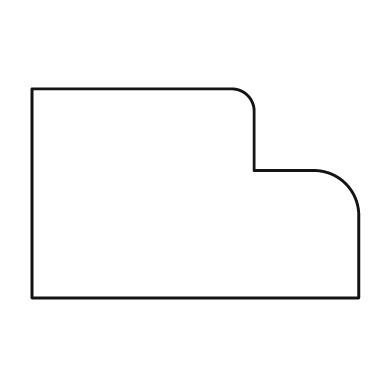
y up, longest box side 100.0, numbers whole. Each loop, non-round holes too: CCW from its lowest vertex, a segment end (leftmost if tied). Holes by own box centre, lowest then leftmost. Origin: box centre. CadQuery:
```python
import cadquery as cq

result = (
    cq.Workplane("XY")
    .moveTo(-50.0, -32.0)
    .lineTo(50.0, -32.0)
    .lineTo(50.0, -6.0)
    .threePointArc((46.0, 3.0), (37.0, 7.0))
    .lineTo(18.0, 7.0)
    .lineTo(18.0, 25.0)
    .threePointArc((16.0, 30.0), (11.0, 32.0))
    .lineTo(-50.0, 32.0)
    .close()
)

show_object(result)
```